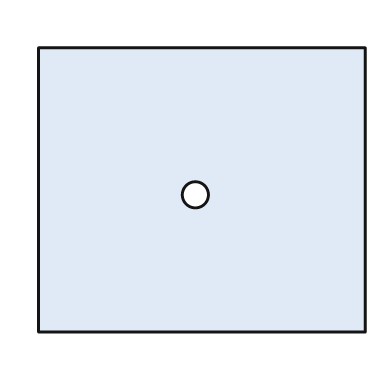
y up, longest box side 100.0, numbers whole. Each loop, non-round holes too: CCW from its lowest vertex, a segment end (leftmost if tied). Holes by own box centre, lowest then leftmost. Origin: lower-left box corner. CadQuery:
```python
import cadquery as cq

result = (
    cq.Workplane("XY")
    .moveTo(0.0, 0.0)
    .lineTo(100.0, 0.0)
    .lineTo(100.0, 87.0)
    .lineTo(0.0, 87.0)
    .close()
    .moveTo(48.0, 42.0)
    .circle(4.0)
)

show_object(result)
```